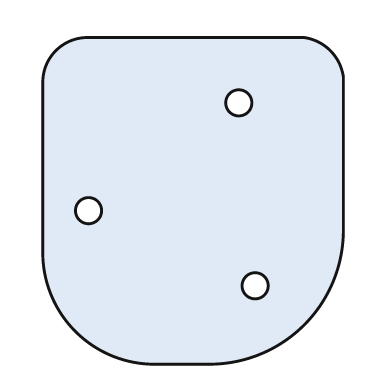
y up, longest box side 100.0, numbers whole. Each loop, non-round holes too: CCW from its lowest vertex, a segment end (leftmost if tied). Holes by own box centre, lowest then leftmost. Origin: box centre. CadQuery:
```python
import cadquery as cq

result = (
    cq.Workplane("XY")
    .moveTo(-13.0, -50.0)
    .lineTo(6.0, -50.0)
    .threePointArc((34.0, -38.0), (46.0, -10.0))
    .lineTo(46.0, 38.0)
    .threePointArc((42.0, 46.0), (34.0, 50.0))
    .lineTo(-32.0, 50.0)
    .threePointArc((-42.0, 46.0), (-46.0, 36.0))
    .lineTo(-46.0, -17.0)
    .threePointArc((-36.0, -40.0), (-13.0, -50.0))
    .close()
    .moveTo(19.0, -26.0)
    .circle(4.0)
    .moveTo(-32.0, -3.0)
    .circle(4.0)
    .moveTo(14.0, 30.0)
    .circle(4.0)
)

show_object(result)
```